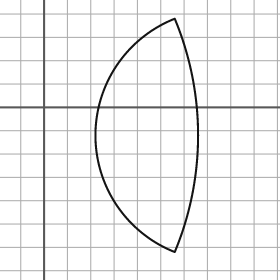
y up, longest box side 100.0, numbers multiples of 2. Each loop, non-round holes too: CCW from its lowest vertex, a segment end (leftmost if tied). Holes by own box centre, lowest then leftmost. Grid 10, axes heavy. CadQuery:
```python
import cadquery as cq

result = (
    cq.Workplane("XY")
    .moveTo(56.0, -62.0)
    .threePointArc((66.0, -12.0), (56.0, 38.0))
    .threePointArc((22.0, -12.0), (56.0, -62.0))
    .close()
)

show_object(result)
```